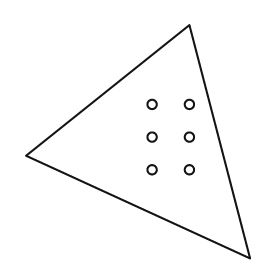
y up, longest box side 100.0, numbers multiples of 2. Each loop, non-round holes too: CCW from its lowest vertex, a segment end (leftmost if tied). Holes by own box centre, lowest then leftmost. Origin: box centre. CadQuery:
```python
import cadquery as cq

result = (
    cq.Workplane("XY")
    .moveTo(48.0, -50.0)
    .lineTo(22.0, 50.0)
    .lineTo(-48.0, -6.0)
    .close()
    .moveTo(6.0, -12.0)
    .circle(2.0)
    .moveTo(22.0, -12.0)
    .circle(2.0)
    .moveTo(6.0, 2.0)
    .circle(2.0)
    .moveTo(22.0, 2.0)
    .circle(2.0)
    .moveTo(6.0, 16.0)
    .circle(2.0)
    .moveTo(22.0, 16.0)
    .circle(2.0)
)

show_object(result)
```